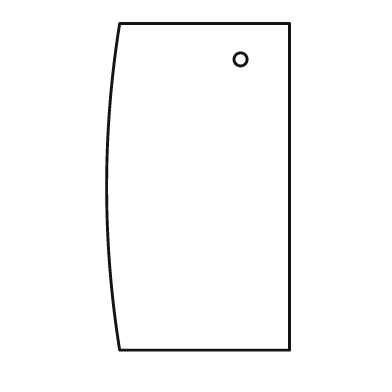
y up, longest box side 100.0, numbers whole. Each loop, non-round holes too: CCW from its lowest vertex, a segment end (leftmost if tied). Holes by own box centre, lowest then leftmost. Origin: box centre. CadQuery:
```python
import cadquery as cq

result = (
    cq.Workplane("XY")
    .moveTo(-24.0, -50.0)
    .lineTo(28.0, -50.0)
    .lineTo(28.0, 50.0)
    .lineTo(-24.0, 50.0)
    .threePointArc((-28.0, 0.0), (-24.0, -50.0))
    .close()
    .moveTo(13.0, 39.0)
    .circle(2.0)
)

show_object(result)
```